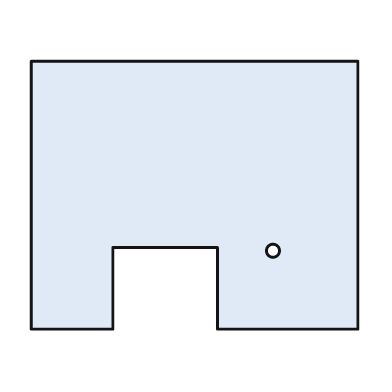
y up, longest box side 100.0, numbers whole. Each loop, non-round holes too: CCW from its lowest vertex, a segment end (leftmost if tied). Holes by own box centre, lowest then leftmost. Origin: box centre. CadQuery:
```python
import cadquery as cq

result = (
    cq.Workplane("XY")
    .moveTo(-50.0, -41.0)
    .lineTo(-25.0, -41.0)
    .lineTo(-25.0, -16.0)
    .lineTo(7.0, -16.0)
    .lineTo(7.0, -41.0)
    .lineTo(50.0, -41.0)
    .lineTo(50.0, 41.0)
    .lineTo(-50.0, 41.0)
    .close()
    .moveTo(24.0, -17.0)
    .circle(2.0)
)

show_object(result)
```